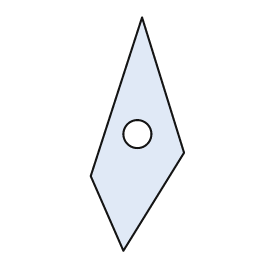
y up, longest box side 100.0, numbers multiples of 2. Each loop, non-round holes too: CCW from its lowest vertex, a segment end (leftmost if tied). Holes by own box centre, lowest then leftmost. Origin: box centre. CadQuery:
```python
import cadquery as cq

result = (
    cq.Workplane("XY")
    .moveTo(-6.0, -50.0)
    .lineTo(20.0, -8.0)
    .lineTo(2.0, 50.0)
    .lineTo(-20.0, -18.0)
    .close()
    .moveTo(0.0, 0.0)
    .circle(6.0)
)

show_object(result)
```